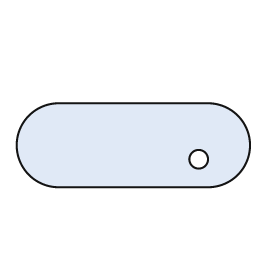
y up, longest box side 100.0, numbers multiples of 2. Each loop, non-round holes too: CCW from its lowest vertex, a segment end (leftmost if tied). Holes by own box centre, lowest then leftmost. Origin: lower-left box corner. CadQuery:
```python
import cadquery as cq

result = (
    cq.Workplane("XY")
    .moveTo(18.0, 0.0)
    .lineTo(82.0, 0.0)
    .threePointArc((100.0, 18.0), (82.0, 36.0))
    .lineTo(18.0, 36.0)
    .threePointArc((0.0, 18.0), (18.0, 0.0))
    .close()
    .moveTo(78.0, 12.0)
    .circle(4.0)
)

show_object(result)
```